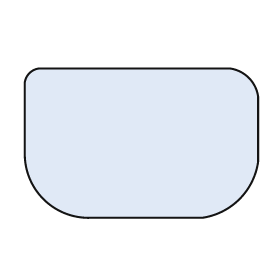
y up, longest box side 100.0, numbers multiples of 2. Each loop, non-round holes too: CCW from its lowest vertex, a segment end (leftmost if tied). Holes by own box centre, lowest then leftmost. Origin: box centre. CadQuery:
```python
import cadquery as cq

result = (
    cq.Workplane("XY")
    .moveTo(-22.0, -32.0)
    .lineTo(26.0, -32.0)
    .threePointArc((42.0, -24.0), (50.0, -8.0))
    .lineTo(50.0, 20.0)
    .threePointArc((46.0, 28.0), (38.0, 32.0))
    .lineTo(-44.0, 32.0)
    .threePointArc((-48.0, 30.0), (-50.0, 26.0))
    .lineTo(-50.0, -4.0)
    .threePointArc((-42.0, -24.0), (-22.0, -32.0))
    .close()
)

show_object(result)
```